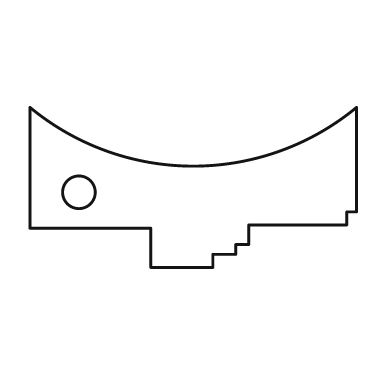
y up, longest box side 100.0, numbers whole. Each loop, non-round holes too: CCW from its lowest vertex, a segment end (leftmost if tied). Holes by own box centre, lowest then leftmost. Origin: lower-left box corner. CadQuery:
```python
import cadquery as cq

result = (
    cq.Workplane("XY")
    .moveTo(37.0, 0.0)
    .lineTo(56.0, 0.0)
    .lineTo(56.0, 4.0)
    .lineTo(63.0, 4.0)
    .lineTo(63.0, 7.0)
    .lineTo(67.0, 7.0)
    .lineTo(67.0, 13.0)
    .lineTo(97.0, 13.0)
    .lineTo(97.0, 17.0)
    .lineTo(100.0, 17.0)
    .lineTo(100.0, 49.0)
    .threePointArc((50.0, 31.0), (0.0, 49.0))
    .lineTo(0.0, 12.0)
    .lineTo(37.0, 12.0)
    .close()
    .moveTo(15.0, 23.0)
    .circle(5.0)
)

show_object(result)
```